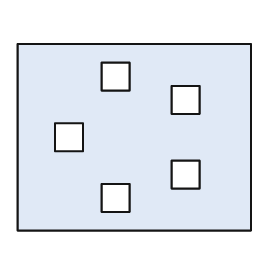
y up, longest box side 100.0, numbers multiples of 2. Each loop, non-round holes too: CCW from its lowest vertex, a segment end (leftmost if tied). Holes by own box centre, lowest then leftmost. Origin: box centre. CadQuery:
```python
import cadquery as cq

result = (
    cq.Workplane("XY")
    .moveTo(-50.0, -40.0)
    .lineTo(50.0, -40.0)
    .lineTo(50.0, 40.0)
    .lineTo(-50.0, 40.0)
    .close()
    .moveTo(-14.0, -32.0)
    .lineTo(-2.0, -32.0)
    .lineTo(-2.0, -20.0)
    .lineTo(-14.0, -20.0)
    .close()
    .moveTo(16.0, -22.0)
    .lineTo(28.0, -22.0)
    .lineTo(28.0, -10.0)
    .lineTo(16.0, -10.0)
    .close()
    .moveTo(-34.0, -6.0)
    .lineTo(-22.0, -6.0)
    .lineTo(-22.0, 6.0)
    .lineTo(-34.0, 6.0)
    .close()
    .moveTo(16.0, 10.0)
    .lineTo(28.0, 10.0)
    .lineTo(28.0, 22.0)
    .lineTo(16.0, 22.0)
    .close()
    .moveTo(-14.0, 20.0)
    .lineTo(-2.0, 20.0)
    .lineTo(-2.0, 32.0)
    .lineTo(-14.0, 32.0)
    .close()
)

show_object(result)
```